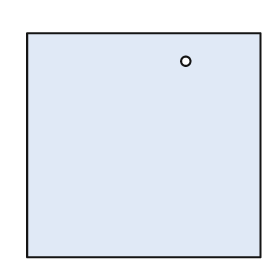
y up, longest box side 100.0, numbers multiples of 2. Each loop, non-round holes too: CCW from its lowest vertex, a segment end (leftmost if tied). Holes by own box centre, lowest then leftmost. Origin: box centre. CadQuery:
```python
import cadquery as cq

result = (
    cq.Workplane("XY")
    .moveTo(-50.0, -48.0)
    .lineTo(50.0, -48.0)
    .lineTo(50.0, 48.0)
    .lineTo(-50.0, 48.0)
    .close()
    .moveTo(18.0, 36.0)
    .circle(2.0)
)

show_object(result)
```